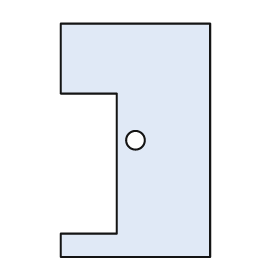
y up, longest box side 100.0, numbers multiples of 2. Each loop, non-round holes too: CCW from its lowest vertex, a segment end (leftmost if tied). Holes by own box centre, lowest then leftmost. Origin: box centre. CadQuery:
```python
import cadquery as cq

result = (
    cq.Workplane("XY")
    .moveTo(-32.0, -50.0)
    .lineTo(32.0, -50.0)
    .lineTo(32.0, 50.0)
    .lineTo(-32.0, 50.0)
    .lineTo(-32.0, 20.0)
    .lineTo(-8.0, 20.0)
    .lineTo(-8.0, -40.0)
    .lineTo(-32.0, -40.0)
    .close()
    .moveTo(0.0, 0.0)
    .circle(4.0)
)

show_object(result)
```